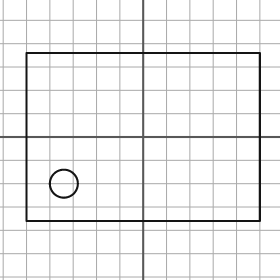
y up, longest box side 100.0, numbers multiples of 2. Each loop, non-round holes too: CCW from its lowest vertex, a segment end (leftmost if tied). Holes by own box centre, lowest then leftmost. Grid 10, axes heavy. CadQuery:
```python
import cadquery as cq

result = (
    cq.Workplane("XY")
    .moveTo(-50.0, -36.0)
    .lineTo(50.0, -36.0)
    .lineTo(50.0, 36.0)
    .lineTo(-50.0, 36.0)
    .close()
    .moveTo(-34.0, -20.0)
    .circle(6.0)
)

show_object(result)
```